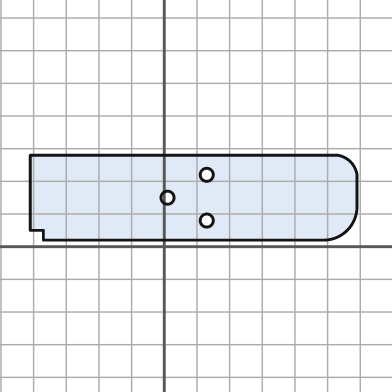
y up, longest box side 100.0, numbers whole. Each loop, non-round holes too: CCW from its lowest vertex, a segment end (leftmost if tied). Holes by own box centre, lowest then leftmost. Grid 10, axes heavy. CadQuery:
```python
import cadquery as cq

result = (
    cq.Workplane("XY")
    .moveTo(-37.0, 2.0)
    .lineTo(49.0, 2.0)
    .threePointArc((56.0, 5.0), (59.0, 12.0))
    .lineTo(59.0, 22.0)
    .threePointArc((57.0, 26.0), (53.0, 28.0))
    .lineTo(-41.0, 28.0)
    .lineTo(-41.0, 5.0)
    .lineTo(-37.0, 5.0)
    .close()
    .moveTo(13.0, 8.0)
    .circle(2.0)
    .moveTo(1.0, 15.0)
    .circle(2.0)
    .moveTo(13.0, 22.0)
    .circle(2.0)
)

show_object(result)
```